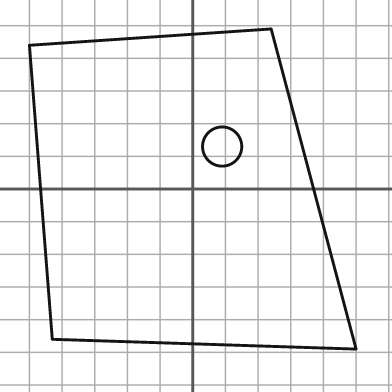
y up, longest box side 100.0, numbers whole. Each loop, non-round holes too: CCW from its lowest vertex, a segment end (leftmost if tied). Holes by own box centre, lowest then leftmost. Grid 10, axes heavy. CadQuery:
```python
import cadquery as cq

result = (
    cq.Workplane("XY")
    .moveTo(50.0, -49.0)
    .lineTo(24.0, 49.0)
    .lineTo(-50.0, 44.0)
    .lineTo(-43.0, -46.0)
    .close()
    .moveTo(9.0, 13.0)
    .circle(6.0)
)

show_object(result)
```